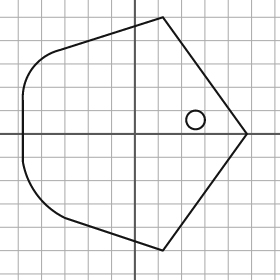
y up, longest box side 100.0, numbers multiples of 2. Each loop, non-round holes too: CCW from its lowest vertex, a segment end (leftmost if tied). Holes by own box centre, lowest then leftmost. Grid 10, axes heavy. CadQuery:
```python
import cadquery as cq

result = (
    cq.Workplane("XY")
    .moveTo(12.0, -50.0)
    .lineTo(48.0, 0.0)
    .lineTo(12.0, 50.0)
    .lineTo(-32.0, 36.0)
    .threePointArc((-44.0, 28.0), (-48.0, 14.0))
    .lineTo(-48.0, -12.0)
    .threePointArc((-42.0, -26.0), (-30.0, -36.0))
    .close()
    .moveTo(26.0, 6.0)
    .circle(4.0)
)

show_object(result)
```